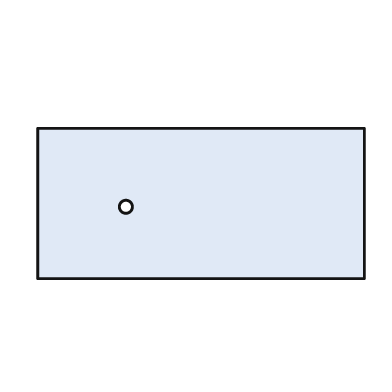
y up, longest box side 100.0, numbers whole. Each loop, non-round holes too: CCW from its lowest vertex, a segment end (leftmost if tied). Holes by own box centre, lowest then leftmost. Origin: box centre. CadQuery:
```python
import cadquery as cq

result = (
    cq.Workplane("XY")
    .moveTo(-50.0, -23.0)
    .lineTo(50.0, -23.0)
    .lineTo(50.0, 23.0)
    .lineTo(-50.0, 23.0)
    .close()
    .moveTo(-23.0, -1.0)
    .circle(2.0)
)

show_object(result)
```